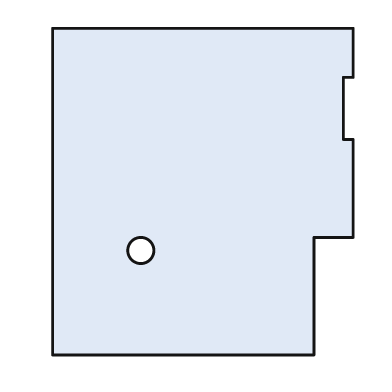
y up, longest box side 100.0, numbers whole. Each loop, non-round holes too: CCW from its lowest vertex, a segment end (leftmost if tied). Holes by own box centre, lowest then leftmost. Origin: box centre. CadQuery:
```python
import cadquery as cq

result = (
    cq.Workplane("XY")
    .moveTo(-46.0, -50.0)
    .lineTo(34.0, -50.0)
    .lineTo(34.0, -14.0)
    .lineTo(46.0, -14.0)
    .lineTo(46.0, 16.0)
    .lineTo(43.0, 16.0)
    .lineTo(43.0, 35.0)
    .lineTo(46.0, 35.0)
    .lineTo(46.0, 50.0)
    .lineTo(-46.0, 50.0)
    .close()
    .moveTo(-19.0, -18.0)
    .circle(4.0)
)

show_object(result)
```